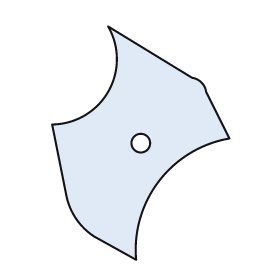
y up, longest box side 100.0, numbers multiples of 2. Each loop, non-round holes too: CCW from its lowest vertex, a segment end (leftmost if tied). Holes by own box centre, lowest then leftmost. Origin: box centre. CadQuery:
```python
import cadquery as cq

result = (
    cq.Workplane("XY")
    .moveTo(-2.0, -50.0)
    .threePointArc((8.0, -16.0), (38.0, 2.0))
    .lineTo(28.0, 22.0)
    .threePointArc((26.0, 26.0), (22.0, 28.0))
    .lineTo(-14.0, 50.0)
    .threePointArc((-14.0, 22.0), (-38.0, 8.0))
    .lineTo(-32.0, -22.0)
    .threePointArc((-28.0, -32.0), (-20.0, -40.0))
    .close()
    .moveTo(0.0, 0.0)
    .circle(4.0)
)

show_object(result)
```